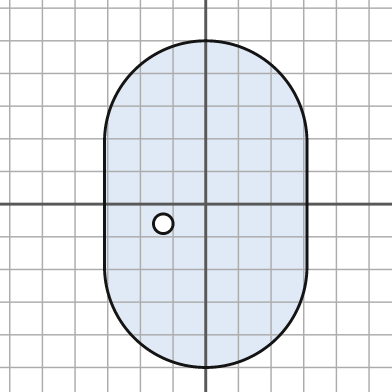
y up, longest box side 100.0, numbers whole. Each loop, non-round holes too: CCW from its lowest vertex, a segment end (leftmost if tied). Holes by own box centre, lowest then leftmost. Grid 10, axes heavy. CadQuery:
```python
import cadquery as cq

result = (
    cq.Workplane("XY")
    .moveTo(-31.0, -19.0)
    .threePointArc((0.0, -50.0), (31.0, -19.0))
    .lineTo(31.0, 19.0)
    .threePointArc((0.0, 50.0), (-31.0, 19.0))
    .close()
    .moveTo(-13.0, -6.0)
    .circle(3.0)
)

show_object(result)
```